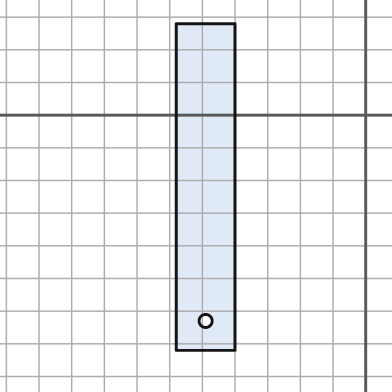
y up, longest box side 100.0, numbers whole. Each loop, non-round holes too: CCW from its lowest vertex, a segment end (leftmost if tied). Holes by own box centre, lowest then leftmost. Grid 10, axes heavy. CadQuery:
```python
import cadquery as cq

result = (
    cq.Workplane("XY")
    .moveTo(-58.0, -72.0)
    .lineTo(-40.0, -72.0)
    .lineTo(-40.0, 28.0)
    .lineTo(-58.0, 28.0)
    .close()
    .moveTo(-49.0, -63.0)
    .circle(2.0)
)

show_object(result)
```